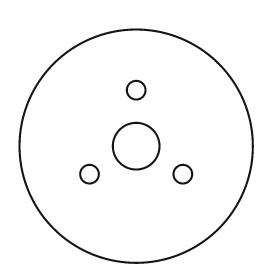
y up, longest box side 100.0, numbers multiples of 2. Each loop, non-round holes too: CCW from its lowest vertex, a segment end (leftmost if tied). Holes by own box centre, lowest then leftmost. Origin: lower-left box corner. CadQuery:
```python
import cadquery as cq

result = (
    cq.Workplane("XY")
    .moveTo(50.0, 50.0)
    .circle(50.0)
    .moveTo(30.0, 38.0)
    .circle(4.0)
    .moveTo(70.0, 38.0)
    .circle(4.0)
    .moveTo(50.0, 50.0)
    .circle(10.0)
    .moveTo(50.0, 74.0)
    .circle(4.0)
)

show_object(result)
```